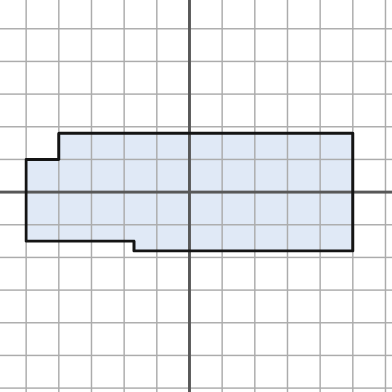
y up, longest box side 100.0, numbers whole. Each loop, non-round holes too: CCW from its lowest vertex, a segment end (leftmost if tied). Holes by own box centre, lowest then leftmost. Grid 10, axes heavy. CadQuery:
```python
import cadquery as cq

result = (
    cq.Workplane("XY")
    .moveTo(-17.0, -18.0)
    .lineTo(50.0, -18.0)
    .lineTo(50.0, 18.0)
    .lineTo(-40.0, 18.0)
    .lineTo(-40.0, 10.0)
    .lineTo(-50.0, 10.0)
    .lineTo(-50.0, -15.0)
    .lineTo(-17.0, -15.0)
    .close()
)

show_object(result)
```